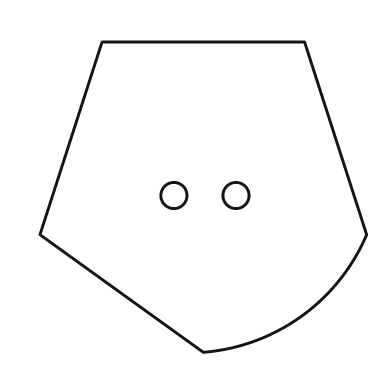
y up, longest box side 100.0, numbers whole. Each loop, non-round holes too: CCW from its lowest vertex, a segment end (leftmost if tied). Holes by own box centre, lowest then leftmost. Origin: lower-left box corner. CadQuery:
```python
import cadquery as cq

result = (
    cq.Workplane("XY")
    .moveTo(50.0, 0.0)
    .threePointArc((80.0, 11.0), (100.0, 36.0))
    .lineTo(81.0, 95.0)
    .lineTo(19.0, 95.0)
    .lineTo(0.0, 36.0)
    .close()
    .moveTo(41.0, 48.0)
    .circle(4.0)
    .moveTo(60.0, 48.0)
    .circle(4.0)
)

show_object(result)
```